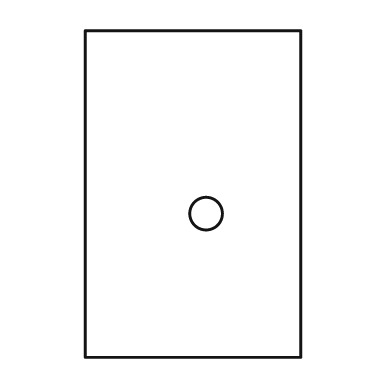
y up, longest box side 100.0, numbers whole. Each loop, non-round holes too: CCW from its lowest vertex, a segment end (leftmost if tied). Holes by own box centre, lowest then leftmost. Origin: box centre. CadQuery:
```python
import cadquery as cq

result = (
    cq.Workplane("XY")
    .moveTo(-33.0, -50.0)
    .lineTo(33.0, -50.0)
    .lineTo(33.0, 50.0)
    .lineTo(-33.0, 50.0)
    .close()
    .moveTo(4.0, -6.0)
    .circle(5.0)
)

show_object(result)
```